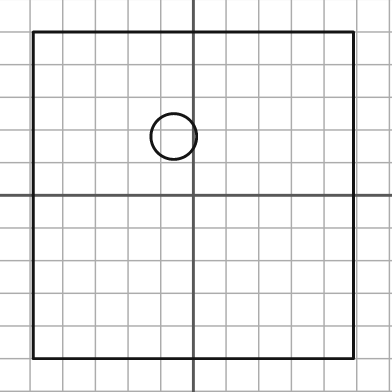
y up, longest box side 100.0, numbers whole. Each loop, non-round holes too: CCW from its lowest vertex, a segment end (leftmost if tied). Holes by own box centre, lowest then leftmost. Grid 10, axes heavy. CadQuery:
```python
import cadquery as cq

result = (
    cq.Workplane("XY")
    .moveTo(-49.0, -50.0)
    .lineTo(49.0, -50.0)
    .lineTo(49.0, 50.0)
    .lineTo(-49.0, 50.0)
    .close()
    .moveTo(-6.0, 18.0)
    .circle(7.0)
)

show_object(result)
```